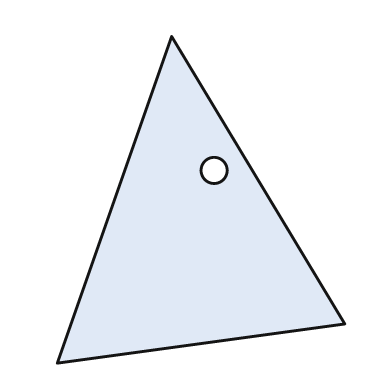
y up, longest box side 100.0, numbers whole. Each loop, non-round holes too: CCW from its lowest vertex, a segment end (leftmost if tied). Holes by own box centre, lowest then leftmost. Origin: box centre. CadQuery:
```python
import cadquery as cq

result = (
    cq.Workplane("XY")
    .moveTo(-44.0, -50.0)
    .lineTo(44.0, -38.0)
    .lineTo(-9.0, 50.0)
    .close()
    .moveTo(4.0, 9.0)
    .circle(4.0)
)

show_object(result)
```